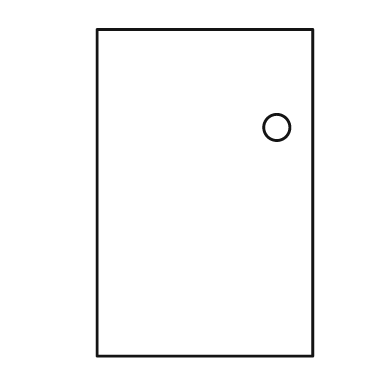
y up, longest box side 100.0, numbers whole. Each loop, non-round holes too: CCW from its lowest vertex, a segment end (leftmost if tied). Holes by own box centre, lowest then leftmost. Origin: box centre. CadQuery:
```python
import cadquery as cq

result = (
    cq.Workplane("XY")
    .moveTo(-33.0, -50.0)
    .lineTo(33.0, -50.0)
    .lineTo(33.0, 50.0)
    .lineTo(-33.0, 50.0)
    .close()
    .moveTo(22.0, 20.0)
    .circle(4.0)
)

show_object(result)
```